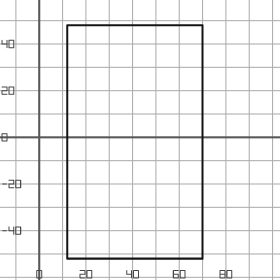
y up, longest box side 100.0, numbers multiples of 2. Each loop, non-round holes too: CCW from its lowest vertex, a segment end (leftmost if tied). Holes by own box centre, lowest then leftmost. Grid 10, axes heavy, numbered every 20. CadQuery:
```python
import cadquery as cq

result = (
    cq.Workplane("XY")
    .moveTo(12.0, -52.0)
    .lineTo(70.0, -52.0)
    .lineTo(70.0, 48.0)
    .lineTo(12.0, 48.0)
    .close()
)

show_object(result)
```